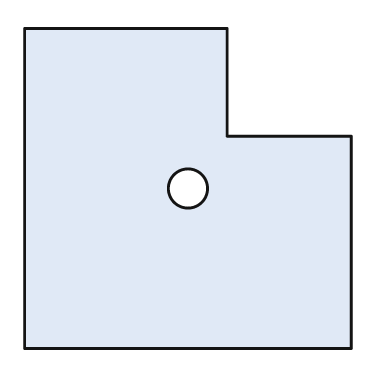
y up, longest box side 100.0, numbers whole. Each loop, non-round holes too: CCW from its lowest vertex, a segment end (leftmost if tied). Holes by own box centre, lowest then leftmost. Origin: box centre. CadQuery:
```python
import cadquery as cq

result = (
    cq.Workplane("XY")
    .moveTo(-50.0, -49.0)
    .lineTo(50.0, -49.0)
    .lineTo(50.0, 16.0)
    .lineTo(12.0, 16.0)
    .lineTo(12.0, 49.0)
    .lineTo(-50.0, 49.0)
    .close()
    .moveTo(0.0, 0.0)
    .circle(6.0)
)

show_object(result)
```